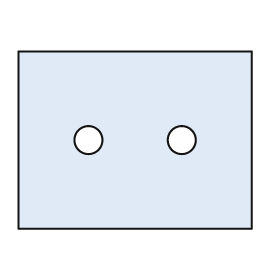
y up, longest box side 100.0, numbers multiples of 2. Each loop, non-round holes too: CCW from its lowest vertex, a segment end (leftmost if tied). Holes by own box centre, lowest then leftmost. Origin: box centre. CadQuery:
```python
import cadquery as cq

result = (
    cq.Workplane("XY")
    .moveTo(-50.0, -38.0)
    .lineTo(50.0, -38.0)
    .lineTo(50.0, 38.0)
    .lineTo(-50.0, 38.0)
    .close()
    .moveTo(-20.0, 0.0)
    .circle(6.0)
    .moveTo(20.0, 0.0)
    .circle(6.0)
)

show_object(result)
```